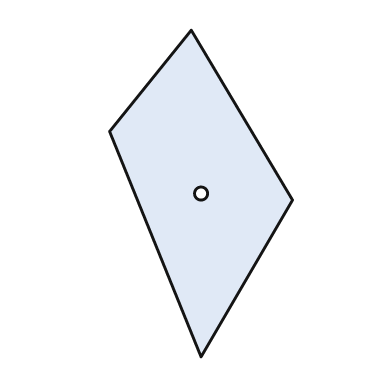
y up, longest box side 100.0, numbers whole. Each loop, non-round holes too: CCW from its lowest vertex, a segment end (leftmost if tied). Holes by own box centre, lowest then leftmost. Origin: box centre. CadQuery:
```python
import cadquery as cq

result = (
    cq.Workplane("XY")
    .moveTo(0.0, -50.0)
    .lineTo(28.0, -2.0)
    .lineTo(-3.0, 50.0)
    .lineTo(-28.0, 19.0)
    .close()
    .moveTo(0.0, 0.0)
    .circle(2.0)
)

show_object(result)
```